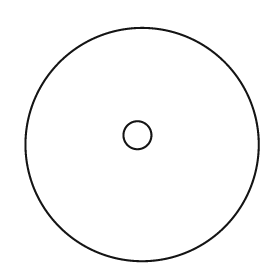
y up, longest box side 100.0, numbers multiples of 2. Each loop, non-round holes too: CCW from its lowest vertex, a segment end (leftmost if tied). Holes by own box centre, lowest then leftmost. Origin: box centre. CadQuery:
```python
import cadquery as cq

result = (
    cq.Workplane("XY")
    .moveTo(0.0, 0.0)
    .circle(50.0)
    .moveTo(-2.0, 4.0)
    .circle(6.0)
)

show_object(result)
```